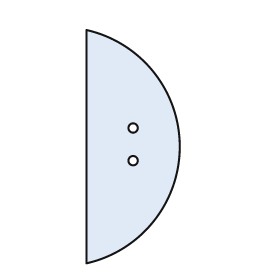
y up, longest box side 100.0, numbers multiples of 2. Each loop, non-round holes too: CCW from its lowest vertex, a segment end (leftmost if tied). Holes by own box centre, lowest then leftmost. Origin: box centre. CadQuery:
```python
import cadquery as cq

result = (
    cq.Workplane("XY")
    .moveTo(-20.0, -50.0)
    .threePointArc((20.0, 0.0), (-20.0, 50.0))
    .close()
    .moveTo(0.0, -6.0)
    .circle(2.0)
    .moveTo(0.0, 8.0)
    .circle(2.0)
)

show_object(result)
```